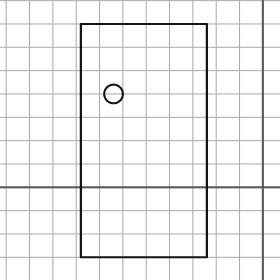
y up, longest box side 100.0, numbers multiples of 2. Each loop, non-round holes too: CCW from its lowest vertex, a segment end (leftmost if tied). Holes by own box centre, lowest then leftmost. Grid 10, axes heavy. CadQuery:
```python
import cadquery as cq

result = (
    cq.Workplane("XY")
    .moveTo(-78.0, -30.0)
    .lineTo(-24.0, -30.0)
    .lineTo(-24.0, 70.0)
    .lineTo(-78.0, 70.0)
    .close()
    .moveTo(-64.0, 40.0)
    .circle(4.0)
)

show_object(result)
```